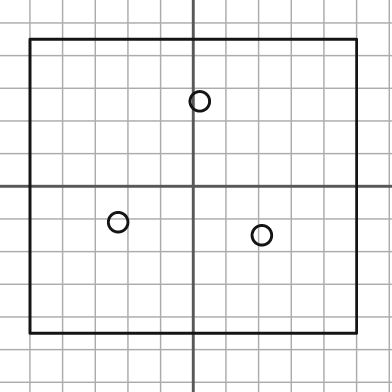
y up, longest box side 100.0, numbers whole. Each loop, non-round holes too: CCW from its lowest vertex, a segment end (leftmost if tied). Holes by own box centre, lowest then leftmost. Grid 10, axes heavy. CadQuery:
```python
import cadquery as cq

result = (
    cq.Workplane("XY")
    .moveTo(-50.0, -45.0)
    .lineTo(50.0, -45.0)
    .lineTo(50.0, 45.0)
    .lineTo(-50.0, 45.0)
    .close()
    .moveTo(21.0, -15.0)
    .circle(3.0)
    .moveTo(-23.0, -11.0)
    .circle(3.0)
    .moveTo(2.0, 26.0)
    .circle(3.0)
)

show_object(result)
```